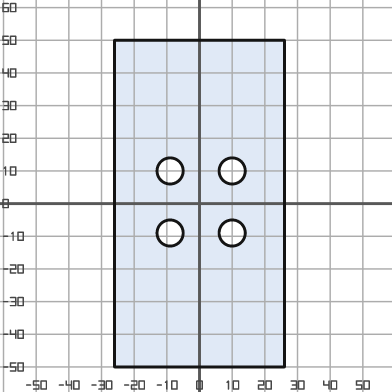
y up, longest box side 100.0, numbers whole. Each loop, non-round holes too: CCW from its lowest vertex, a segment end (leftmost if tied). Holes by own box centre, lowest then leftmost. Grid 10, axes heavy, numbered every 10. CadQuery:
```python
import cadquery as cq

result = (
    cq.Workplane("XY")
    .moveTo(-26.0, -50.0)
    .lineTo(26.0, -50.0)
    .lineTo(26.0, 50.0)
    .lineTo(-26.0, 50.0)
    .close()
    .moveTo(-9.0, -9.0)
    .circle(4.0)
    .moveTo(10.0, -9.0)
    .circle(4.0)
    .moveTo(-9.0, 10.0)
    .circle(4.0)
    .moveTo(10.0, 10.0)
    .circle(4.0)
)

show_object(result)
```